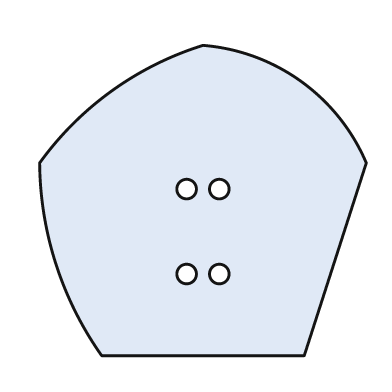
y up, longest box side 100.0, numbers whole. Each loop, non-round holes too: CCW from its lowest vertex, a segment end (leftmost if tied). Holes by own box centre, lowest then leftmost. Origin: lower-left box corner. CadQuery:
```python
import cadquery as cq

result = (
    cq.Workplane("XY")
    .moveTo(19.0, 0.0)
    .lineTo(81.0, 0.0)
    .lineTo(100.0, 59.0)
    .threePointArc((80.0, 84.0), (50.0, 95.0))
    .threePointArc((22.0, 81.0), (0.0, 59.0))
    .threePointArc((5.0, 28.0), (19.0, 0.0))
    .close()
    .moveTo(45.0, 25.0)
    .circle(3.0)
    .moveTo(55.0, 25.0)
    .circle(3.0)
    .moveTo(45.0, 51.0)
    .circle(3.0)
    .moveTo(55.0, 51.0)
    .circle(3.0)
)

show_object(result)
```